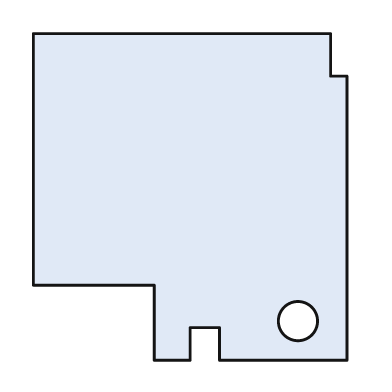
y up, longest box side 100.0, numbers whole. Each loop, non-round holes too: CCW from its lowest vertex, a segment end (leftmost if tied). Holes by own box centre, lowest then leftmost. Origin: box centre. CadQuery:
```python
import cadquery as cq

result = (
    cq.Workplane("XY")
    .moveTo(-11.0, -50.0)
    .lineTo(0.0, -50.0)
    .lineTo(0.0, -40.0)
    .lineTo(9.0, -40.0)
    .lineTo(9.0, -50.0)
    .lineTo(48.0, -50.0)
    .lineTo(48.0, 37.0)
    .lineTo(43.0, 37.0)
    .lineTo(43.0, 50.0)
    .lineTo(-48.0, 50.0)
    .lineTo(-48.0, -27.0)
    .lineTo(-11.0, -27.0)
    .close()
    .moveTo(33.0, -38.0)
    .circle(6.0)
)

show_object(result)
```